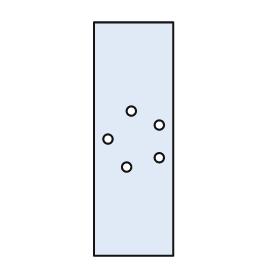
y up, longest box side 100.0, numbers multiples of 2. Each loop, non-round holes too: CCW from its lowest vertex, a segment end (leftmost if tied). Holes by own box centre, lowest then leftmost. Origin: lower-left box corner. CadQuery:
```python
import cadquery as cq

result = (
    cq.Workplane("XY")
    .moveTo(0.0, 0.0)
    .lineTo(34.0, 0.0)
    .lineTo(34.0, 100.0)
    .lineTo(0.0, 100.0)
    .close()
    .moveTo(14.0, 38.0)
    .circle(2.0)
    .moveTo(28.0, 42.0)
    .circle(2.0)
    .moveTo(6.0, 50.0)
    .circle(2.0)
    .moveTo(28.0, 56.0)
    .circle(2.0)
    .moveTo(16.0, 62.0)
    .circle(2.0)
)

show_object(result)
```